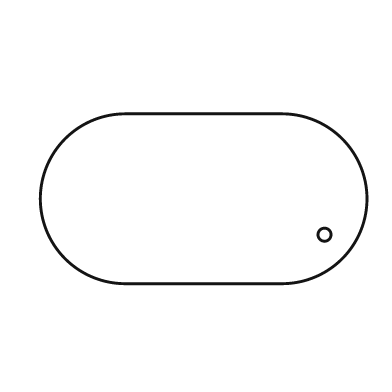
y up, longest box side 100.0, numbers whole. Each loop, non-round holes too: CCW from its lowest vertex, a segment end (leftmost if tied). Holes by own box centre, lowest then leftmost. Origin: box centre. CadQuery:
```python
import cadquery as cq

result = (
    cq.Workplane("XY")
    .moveTo(-24.0, -26.0)
    .lineTo(24.0, -26.0)
    .threePointArc((50.0, 0.0), (24.0, 26.0))
    .lineTo(-24.0, 26.0)
    .threePointArc((-50.0, 0.0), (-24.0, -26.0))
    .close()
    .moveTo(37.0, -11.0)
    .circle(2.0)
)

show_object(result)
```